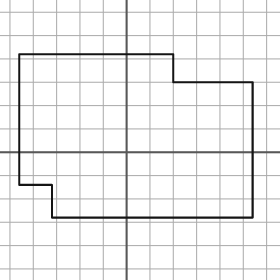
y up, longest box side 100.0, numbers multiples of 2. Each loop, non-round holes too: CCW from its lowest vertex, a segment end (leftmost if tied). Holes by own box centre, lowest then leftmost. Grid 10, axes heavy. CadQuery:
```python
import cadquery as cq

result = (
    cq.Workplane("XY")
    .moveTo(-32.0, -28.0)
    .lineTo(54.0, -28.0)
    .lineTo(54.0, 30.0)
    .lineTo(20.0, 30.0)
    .lineTo(20.0, 42.0)
    .lineTo(-46.0, 42.0)
    .lineTo(-46.0, -14.0)
    .lineTo(-32.0, -14.0)
    .close()
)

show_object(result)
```